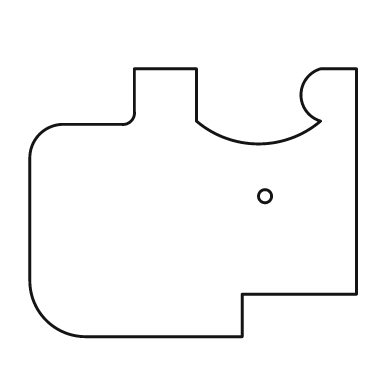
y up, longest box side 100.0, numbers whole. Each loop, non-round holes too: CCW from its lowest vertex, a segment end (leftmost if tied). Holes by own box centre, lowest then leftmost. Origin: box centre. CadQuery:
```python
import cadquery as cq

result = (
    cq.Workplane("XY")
    .moveTo(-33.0, -41.0)
    .lineTo(15.0, -41.0)
    .lineTo(15.0, -28.0)
    .lineTo(50.0, -28.0)
    .lineTo(50.0, 41.0)
    .lineTo(39.0, 41.0)
    .threePointArc((33.0, 33.0), (39.0, 25.0))
    .threePointArc((20.0, 18.0), (1.0, 25.0))
    .lineTo(1.0, 41.0)
    .lineTo(-18.0, 41.0)
    .lineTo(-18.0, 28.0)
    .threePointArc((-19.0, 25.0), (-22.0, 24.0))
    .lineTo(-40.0, 24.0)
    .threePointArc((-47.0, 21.0), (-50.0, 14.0))
    .lineTo(-50.0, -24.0)
    .threePointArc((-45.0, -36.0), (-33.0, -41.0))
    .close()
    .moveTo(22.0, 2.0)
    .circle(2.0)
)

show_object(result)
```